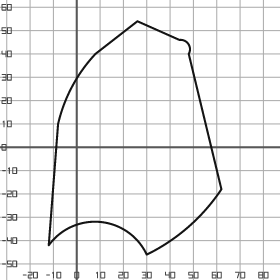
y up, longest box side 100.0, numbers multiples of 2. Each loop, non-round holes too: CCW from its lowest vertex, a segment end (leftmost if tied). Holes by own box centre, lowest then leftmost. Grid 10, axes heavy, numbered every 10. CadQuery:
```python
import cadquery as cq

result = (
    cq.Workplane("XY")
    .moveTo(30.0, -46.0)
    .threePointArc((48.0, -34.0), (62.0, -18.0))
    .lineTo(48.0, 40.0)
    .threePointArc((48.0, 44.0), (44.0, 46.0))
    .lineTo(26.0, 54.0)
    .lineTo(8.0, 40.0)
    .threePointArc((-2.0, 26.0), (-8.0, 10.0))
    .lineTo(-12.0, -42.0)
    .threePointArc((10.0, -32.0), (30.0, -46.0))
    .close()
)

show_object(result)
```